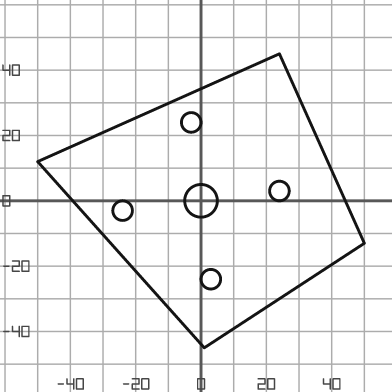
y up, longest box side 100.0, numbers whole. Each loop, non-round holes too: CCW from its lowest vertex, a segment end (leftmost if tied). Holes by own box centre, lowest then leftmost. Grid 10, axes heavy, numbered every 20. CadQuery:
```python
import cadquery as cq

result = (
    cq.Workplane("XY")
    .moveTo(1.0, -45.0)
    .lineTo(50.0, -13.0)
    .lineTo(24.0, 45.0)
    .lineTo(-50.0, 12.0)
    .close()
    .moveTo(3.0, -24.0)
    .circle(3.0)
    .moveTo(-24.0, -3.0)
    .circle(3.0)
    .moveTo(0.0, 0.0)
    .circle(5.0)
    .moveTo(24.0, 3.0)
    .circle(3.0)
    .moveTo(-3.0, 24.0)
    .circle(3.0)
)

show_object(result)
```